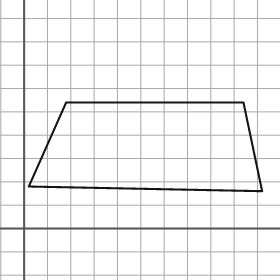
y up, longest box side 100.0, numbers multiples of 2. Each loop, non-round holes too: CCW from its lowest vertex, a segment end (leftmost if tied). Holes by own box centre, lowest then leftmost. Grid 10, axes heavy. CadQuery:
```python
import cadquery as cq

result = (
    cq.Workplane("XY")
    .moveTo(102.0, 16.0)
    .lineTo(94.0, 54.0)
    .lineTo(18.0, 54.0)
    .lineTo(2.0, 18.0)
    .close()
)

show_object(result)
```